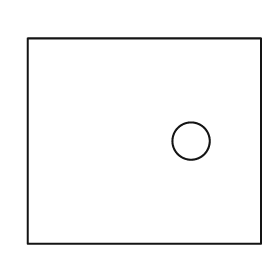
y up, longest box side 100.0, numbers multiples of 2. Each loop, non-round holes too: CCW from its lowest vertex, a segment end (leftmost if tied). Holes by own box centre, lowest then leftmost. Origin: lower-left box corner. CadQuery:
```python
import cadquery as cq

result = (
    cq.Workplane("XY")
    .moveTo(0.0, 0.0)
    .lineTo(100.0, 0.0)
    .lineTo(100.0, 88.0)
    .lineTo(0.0, 88.0)
    .close()
    .moveTo(70.0, 44.0)
    .circle(8.0)
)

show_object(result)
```